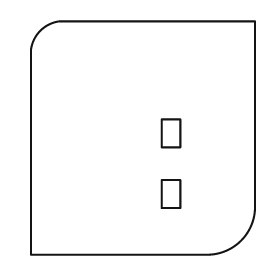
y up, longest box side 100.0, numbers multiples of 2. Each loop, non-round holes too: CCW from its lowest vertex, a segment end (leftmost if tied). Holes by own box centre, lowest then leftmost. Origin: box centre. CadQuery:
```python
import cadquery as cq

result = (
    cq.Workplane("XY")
    .moveTo(-48.0, -50.0)
    .lineTo(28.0, -50.0)
    .threePointArc((42.0, -44.0), (48.0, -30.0))
    .lineTo(48.0, 50.0)
    .lineTo(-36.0, 50.0)
    .threePointArc((-44.0, 46.0), (-48.0, 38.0))
    .close()
    .moveTo(8.0, -30.0)
    .lineTo(16.0, -30.0)
    .lineTo(16.0, -18.0)
    .lineTo(8.0, -18.0)
    .close()
    .moveTo(8.0, -4.0)
    .lineTo(16.0, -4.0)
    .lineTo(16.0, 8.0)
    .lineTo(8.0, 8.0)
    .close()
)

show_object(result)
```